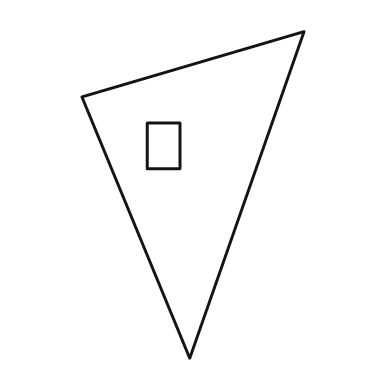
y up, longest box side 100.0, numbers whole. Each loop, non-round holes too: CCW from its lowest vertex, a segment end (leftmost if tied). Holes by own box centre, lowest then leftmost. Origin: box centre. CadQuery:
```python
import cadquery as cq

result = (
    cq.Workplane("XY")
    .moveTo(-1.0, -50.0)
    .lineTo(34.0, 50.0)
    .lineTo(-34.0, 30.0)
    .close()
    .moveTo(-14.0, 8.0)
    .lineTo(-4.0, 8.0)
    .lineTo(-4.0, 22.0)
    .lineTo(-14.0, 22.0)
    .close()
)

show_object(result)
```